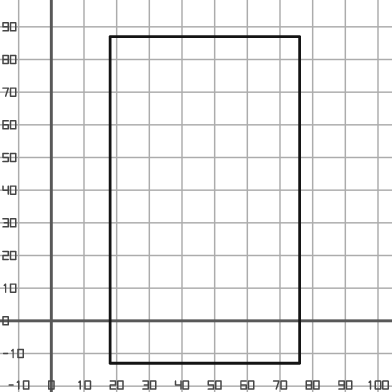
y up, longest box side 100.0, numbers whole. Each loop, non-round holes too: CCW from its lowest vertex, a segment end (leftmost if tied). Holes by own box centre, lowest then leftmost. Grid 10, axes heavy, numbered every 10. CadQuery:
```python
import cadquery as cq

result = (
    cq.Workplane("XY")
    .moveTo(18.0, -13.0)
    .lineTo(76.0, -13.0)
    .lineTo(76.0, 87.0)
    .lineTo(18.0, 87.0)
    .close()
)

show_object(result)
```